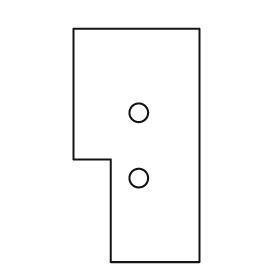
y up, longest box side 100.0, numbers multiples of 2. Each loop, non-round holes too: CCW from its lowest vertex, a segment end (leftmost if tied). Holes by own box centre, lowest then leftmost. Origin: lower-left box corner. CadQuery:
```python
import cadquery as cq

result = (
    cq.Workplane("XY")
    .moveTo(16.0, 0.0)
    .lineTo(54.0, 0.0)
    .lineTo(54.0, 100.0)
    .lineTo(0.0, 100.0)
    .lineTo(0.0, 44.0)
    .lineTo(16.0, 44.0)
    .close()
    .moveTo(28.0, 36.0)
    .circle(4.0)
    .moveTo(28.0, 64.0)
    .circle(4.0)
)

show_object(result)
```